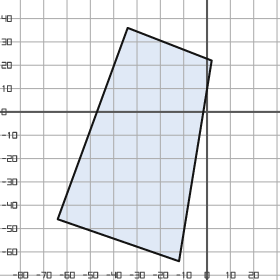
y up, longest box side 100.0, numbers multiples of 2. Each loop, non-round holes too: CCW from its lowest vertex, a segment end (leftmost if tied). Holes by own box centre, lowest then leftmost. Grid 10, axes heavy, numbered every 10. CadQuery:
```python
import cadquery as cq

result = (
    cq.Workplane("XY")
    .moveTo(-12.0, -64.0)
    .lineTo(2.0, 22.0)
    .lineTo(-34.0, 36.0)
    .lineTo(-64.0, -46.0)
    .close()
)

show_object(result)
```